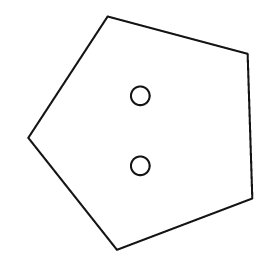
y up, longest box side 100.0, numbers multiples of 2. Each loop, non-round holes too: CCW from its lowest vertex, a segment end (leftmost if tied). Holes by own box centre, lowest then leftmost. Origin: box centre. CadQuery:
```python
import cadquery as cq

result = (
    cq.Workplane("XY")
    .moveTo(-10.0, -50.0)
    .lineTo(48.0, -28.0)
    .lineTo(46.0, 34.0)
    .lineTo(-14.0, 50.0)
    .lineTo(-48.0, -2.0)
    .close()
    .moveTo(0.0, -14.0)
    .circle(4.0)
    .moveTo(0.0, 16.0)
    .circle(4.0)
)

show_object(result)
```